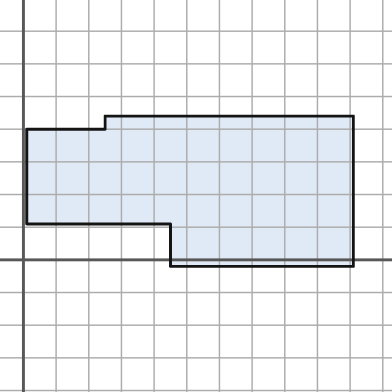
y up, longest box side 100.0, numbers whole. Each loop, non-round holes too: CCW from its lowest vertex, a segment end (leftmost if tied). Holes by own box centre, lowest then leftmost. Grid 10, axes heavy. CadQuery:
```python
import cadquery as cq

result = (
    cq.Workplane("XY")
    .moveTo(45.0, -2.0)
    .lineTo(101.0, -2.0)
    .lineTo(101.0, 44.0)
    .lineTo(25.0, 44.0)
    .lineTo(25.0, 40.0)
    .lineTo(1.0, 40.0)
    .lineTo(1.0, 11.0)
    .lineTo(45.0, 11.0)
    .close()
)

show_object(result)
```